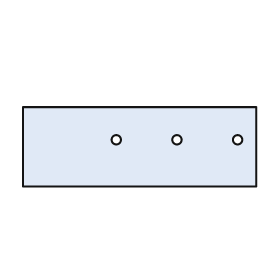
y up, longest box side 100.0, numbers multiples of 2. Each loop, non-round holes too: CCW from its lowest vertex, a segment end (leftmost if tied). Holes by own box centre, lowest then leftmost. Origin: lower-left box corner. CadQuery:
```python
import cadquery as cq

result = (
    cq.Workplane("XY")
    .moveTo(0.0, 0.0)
    .lineTo(100.0, 0.0)
    .lineTo(100.0, 34.0)
    .lineTo(0.0, 34.0)
    .close()
    .moveTo(40.0, 20.0)
    .circle(2.0)
    .moveTo(66.0, 20.0)
    .circle(2.0)
    .moveTo(92.0, 20.0)
    .circle(2.0)
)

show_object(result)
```